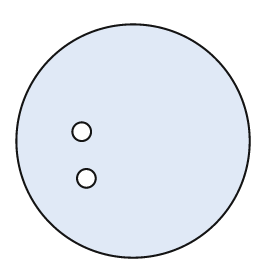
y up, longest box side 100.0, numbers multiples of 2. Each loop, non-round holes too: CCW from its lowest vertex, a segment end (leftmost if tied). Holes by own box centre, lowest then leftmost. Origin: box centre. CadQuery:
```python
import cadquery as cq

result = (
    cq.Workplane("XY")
    .moveTo(0.0, 0.0)
    .circle(50.0)
    .moveTo(-20.0, -16.0)
    .circle(4.0)
    .moveTo(-22.0, 4.0)
    .circle(4.0)
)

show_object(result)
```